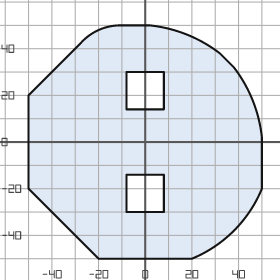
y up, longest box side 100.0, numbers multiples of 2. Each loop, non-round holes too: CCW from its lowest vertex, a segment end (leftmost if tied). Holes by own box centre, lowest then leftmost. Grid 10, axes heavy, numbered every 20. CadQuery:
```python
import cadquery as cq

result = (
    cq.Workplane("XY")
    .moveTo(-20.0, -50.0)
    .lineTo(20.0, -50.0)
    .threePointArc((38.0, -38.0), (50.0, -20.0))
    .lineTo(50.0, 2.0)
    .threePointArc((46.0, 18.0), (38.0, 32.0))
    .lineTo(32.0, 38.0)
    .threePointArc((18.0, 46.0), (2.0, 50.0))
    .lineTo(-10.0, 50.0)
    .threePointArc((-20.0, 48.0), (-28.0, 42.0))
    .lineTo(-50.0, 20.0)
    .lineTo(-50.0, -20.0)
    .close()
    .moveTo(-8.0, -30.0)
    .lineTo(8.0, -30.0)
    .lineTo(8.0, -14.0)
    .lineTo(-8.0, -14.0)
    .close()
    .moveTo(-8.0, 14.0)
    .lineTo(8.0, 14.0)
    .lineTo(8.0, 30.0)
    .lineTo(-8.0, 30.0)
    .close()
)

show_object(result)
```